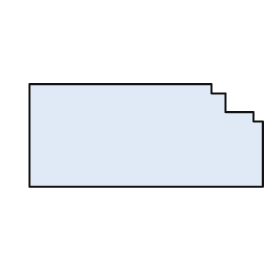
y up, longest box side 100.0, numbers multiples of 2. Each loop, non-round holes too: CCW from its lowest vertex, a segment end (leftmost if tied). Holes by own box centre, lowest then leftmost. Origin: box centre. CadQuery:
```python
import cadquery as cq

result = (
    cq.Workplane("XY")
    .moveTo(-50.0, -22.0)
    .lineTo(50.0, -22.0)
    .lineTo(50.0, 6.0)
    .lineTo(46.0, 6.0)
    .lineTo(46.0, 10.0)
    .lineTo(34.0, 10.0)
    .lineTo(34.0, 18.0)
    .lineTo(28.0, 18.0)
    .lineTo(28.0, 22.0)
    .lineTo(-50.0, 22.0)
    .close()
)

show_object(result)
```